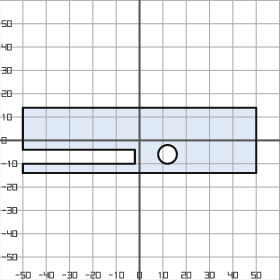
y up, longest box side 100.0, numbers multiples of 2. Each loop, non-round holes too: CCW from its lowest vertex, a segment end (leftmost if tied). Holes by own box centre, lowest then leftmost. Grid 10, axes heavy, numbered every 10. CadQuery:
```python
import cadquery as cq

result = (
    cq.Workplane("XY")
    .moveTo(-50.0, -14.0)
    .lineTo(50.0, -14.0)
    .lineTo(50.0, 14.0)
    .lineTo(-50.0, 14.0)
    .lineTo(-50.0, -4.0)
    .lineTo(-2.0, -4.0)
    .lineTo(-2.0, -10.0)
    .lineTo(-50.0, -10.0)
    .close()
    .moveTo(12.0, -6.0)
    .circle(4.0)
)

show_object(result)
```